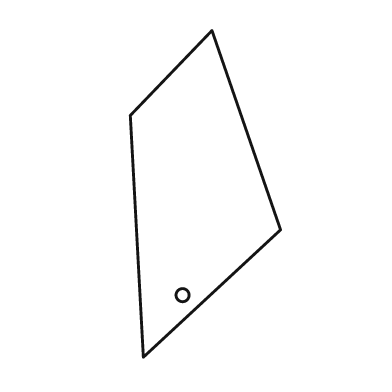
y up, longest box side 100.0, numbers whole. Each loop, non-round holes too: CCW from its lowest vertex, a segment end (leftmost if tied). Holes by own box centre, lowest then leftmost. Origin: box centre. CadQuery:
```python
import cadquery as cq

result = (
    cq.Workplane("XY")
    .moveTo(-19.0, -50.0)
    .lineTo(23.0, -11.0)
    .lineTo(2.0, 50.0)
    .lineTo(-23.0, 24.0)
    .close()
    .moveTo(-7.0, -31.0)
    .circle(2.0)
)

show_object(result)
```